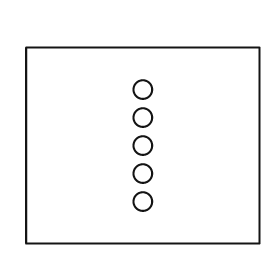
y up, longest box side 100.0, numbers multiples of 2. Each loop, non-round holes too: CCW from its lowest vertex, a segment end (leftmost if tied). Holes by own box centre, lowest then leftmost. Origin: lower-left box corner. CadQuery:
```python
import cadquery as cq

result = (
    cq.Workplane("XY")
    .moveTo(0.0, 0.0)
    .lineTo(100.0, 0.0)
    .lineTo(100.0, 84.0)
    .lineTo(0.0, 84.0)
    .close()
    .moveTo(50.0, 18.0)
    .circle(4.0)
    .moveTo(50.0, 30.0)
    .circle(4.0)
    .moveTo(50.0, 42.0)
    .circle(4.0)
    .moveTo(50.0, 54.0)
    .circle(4.0)
    .moveTo(50.0, 66.0)
    .circle(4.0)
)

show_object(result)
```